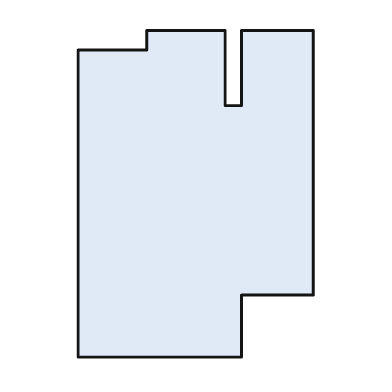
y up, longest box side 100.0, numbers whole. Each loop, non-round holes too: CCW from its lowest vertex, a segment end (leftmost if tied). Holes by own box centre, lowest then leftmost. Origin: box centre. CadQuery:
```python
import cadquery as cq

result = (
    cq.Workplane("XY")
    .moveTo(-36.0, -50.0)
    .lineTo(14.0, -50.0)
    .lineTo(14.0, -31.0)
    .lineTo(36.0, -31.0)
    .lineTo(36.0, 50.0)
    .lineTo(14.0, 50.0)
    .lineTo(14.0, 27.0)
    .lineTo(9.0, 27.0)
    .lineTo(9.0, 50.0)
    .lineTo(-15.0, 50.0)
    .lineTo(-15.0, 44.0)
    .lineTo(-36.0, 44.0)
    .close()
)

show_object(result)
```